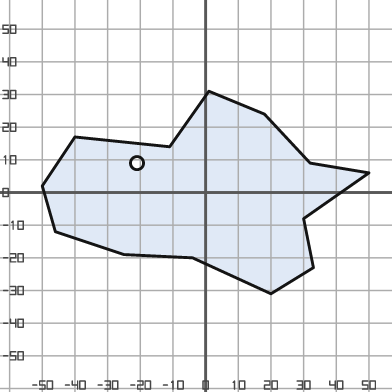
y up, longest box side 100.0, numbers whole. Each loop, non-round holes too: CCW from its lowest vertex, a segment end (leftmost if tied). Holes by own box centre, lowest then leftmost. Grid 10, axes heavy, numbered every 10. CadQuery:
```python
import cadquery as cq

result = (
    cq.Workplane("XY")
    .moveTo(20.0, -31.0)
    .lineTo(33.0, -23.0)
    .lineTo(30.0, -8.0)
    .lineTo(50.0, 6.0)
    .lineTo(32.0, 9.0)
    .lineTo(18.0, 24.0)
    .lineTo(1.0, 31.0)
    .lineTo(-11.0, 14.0)
    .lineTo(-40.0, 17.0)
    .lineTo(-50.0, 2.0)
    .lineTo(-46.0, -12.0)
    .lineTo(-25.0, -19.0)
    .lineTo(-4.0, -20.0)
    .close()
    .moveTo(-21.0, 9.0)
    .circle(2.0)
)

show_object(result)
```